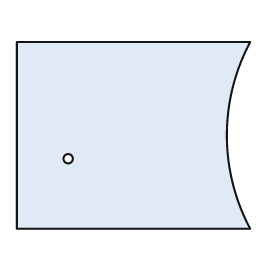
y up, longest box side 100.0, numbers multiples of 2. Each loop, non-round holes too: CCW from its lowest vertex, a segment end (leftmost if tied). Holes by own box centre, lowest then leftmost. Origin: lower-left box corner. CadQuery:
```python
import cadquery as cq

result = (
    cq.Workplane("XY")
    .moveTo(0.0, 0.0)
    .lineTo(100.0, 0.0)
    .threePointArc((90.0, 40.0), (100.0, 80.0))
    .lineTo(0.0, 80.0)
    .close()
    .moveTo(22.0, 30.0)
    .circle(2.0)
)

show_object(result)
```